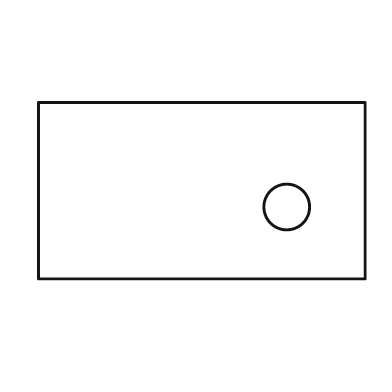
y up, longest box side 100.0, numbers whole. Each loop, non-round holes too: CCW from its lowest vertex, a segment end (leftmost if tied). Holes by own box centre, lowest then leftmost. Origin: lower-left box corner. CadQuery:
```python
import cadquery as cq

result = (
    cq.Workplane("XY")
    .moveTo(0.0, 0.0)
    .lineTo(100.0, 0.0)
    .lineTo(100.0, 54.0)
    .lineTo(0.0, 54.0)
    .close()
    .moveTo(76.0, 22.0)
    .circle(7.0)
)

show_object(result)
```